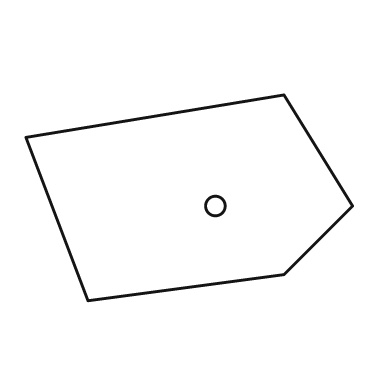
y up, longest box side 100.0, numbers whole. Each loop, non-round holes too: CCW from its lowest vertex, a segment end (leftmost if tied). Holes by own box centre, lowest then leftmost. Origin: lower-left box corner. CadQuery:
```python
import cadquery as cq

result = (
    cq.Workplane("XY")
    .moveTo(19.0, 0.0)
    .lineTo(79.0, 8.0)
    .lineTo(100.0, 29.0)
    .lineTo(79.0, 63.0)
    .lineTo(0.0, 50.0)
    .close()
    .moveTo(58.0, 29.0)
    .circle(3.0)
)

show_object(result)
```